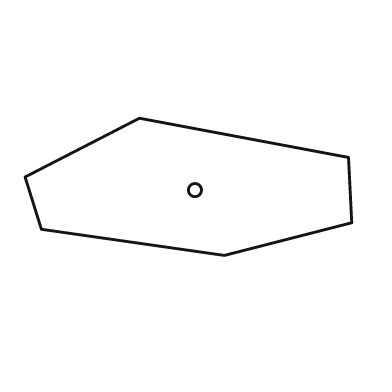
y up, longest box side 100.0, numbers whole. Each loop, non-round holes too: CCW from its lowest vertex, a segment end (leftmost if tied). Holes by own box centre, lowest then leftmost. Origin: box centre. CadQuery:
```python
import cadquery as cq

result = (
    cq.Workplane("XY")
    .moveTo(11.0, -21.0)
    .lineTo(50.0, -11.0)
    .lineTo(49.0, 9.0)
    .lineTo(-15.0, 21.0)
    .lineTo(-50.0, 3.0)
    .lineTo(-45.0, -13.0)
    .close()
    .moveTo(2.0, -1.0)
    .circle(2.0)
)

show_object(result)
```